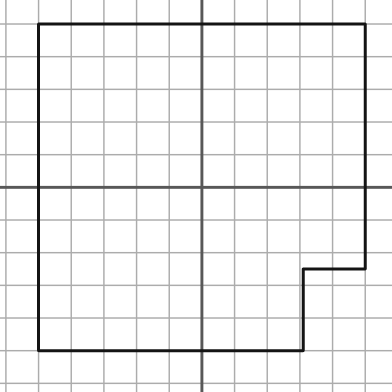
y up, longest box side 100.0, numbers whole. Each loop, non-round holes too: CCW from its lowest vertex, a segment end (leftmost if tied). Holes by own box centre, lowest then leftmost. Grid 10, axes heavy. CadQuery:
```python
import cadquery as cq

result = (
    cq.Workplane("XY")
    .moveTo(-50.0, -50.0)
    .lineTo(31.0, -50.0)
    .lineTo(31.0, -25.0)
    .lineTo(50.0, -25.0)
    .lineTo(50.0, 50.0)
    .lineTo(-50.0, 50.0)
    .close()
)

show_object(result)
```